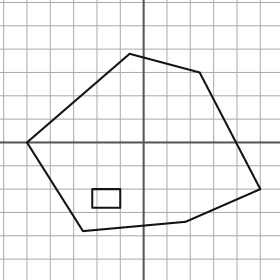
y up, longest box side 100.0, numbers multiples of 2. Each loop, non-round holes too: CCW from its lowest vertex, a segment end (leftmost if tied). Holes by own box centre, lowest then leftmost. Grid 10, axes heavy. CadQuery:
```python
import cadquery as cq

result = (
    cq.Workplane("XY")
    .moveTo(-26.0, -38.0)
    .lineTo(18.0, -34.0)
    .lineTo(50.0, -20.0)
    .lineTo(24.0, 30.0)
    .lineTo(-6.0, 38.0)
    .lineTo(-50.0, 0.0)
    .close()
    .moveTo(-22.0, -28.0)
    .lineTo(-10.0, -28.0)
    .lineTo(-10.0, -20.0)
    .lineTo(-22.0, -20.0)
    .close()
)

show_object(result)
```